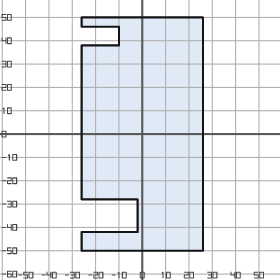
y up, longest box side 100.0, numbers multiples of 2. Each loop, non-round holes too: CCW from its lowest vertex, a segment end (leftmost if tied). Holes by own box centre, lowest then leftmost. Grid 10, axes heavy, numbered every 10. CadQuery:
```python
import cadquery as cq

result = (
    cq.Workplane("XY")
    .moveTo(-26.0, -50.0)
    .lineTo(26.0, -50.0)
    .lineTo(26.0, 50.0)
    .lineTo(-26.0, 50.0)
    .lineTo(-26.0, 46.0)
    .lineTo(-10.0, 46.0)
    .lineTo(-10.0, 38.0)
    .lineTo(-26.0, 38.0)
    .lineTo(-26.0, -28.0)
    .lineTo(-2.0, -28.0)
    .lineTo(-2.0, -42.0)
    .lineTo(-26.0, -42.0)
    .close()
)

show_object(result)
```